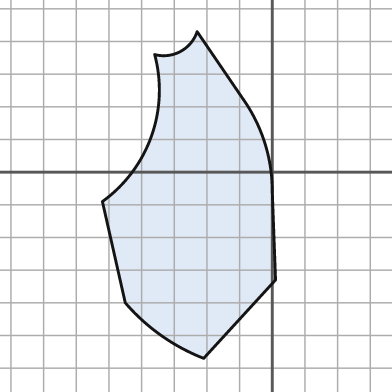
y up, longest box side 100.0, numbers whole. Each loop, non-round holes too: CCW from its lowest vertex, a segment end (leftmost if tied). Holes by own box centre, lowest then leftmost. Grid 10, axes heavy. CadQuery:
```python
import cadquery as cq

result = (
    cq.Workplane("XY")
    .moveTo(-21.0, -57.0)
    .lineTo(1.0, -33.0)
    .lineTo(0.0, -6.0)
    .threePointArc((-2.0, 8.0), (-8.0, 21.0))
    .lineTo(-23.0, 43.0)
    .threePointArc((-28.0, 37.0), (-36.0, 36.0))
    .threePointArc((-37.0, 11.0), (-52.0, -9.0))
    .lineTo(-45.0, -40.0)
    .threePointArc((-34.0, -50.0), (-21.0, -57.0))
    .close()
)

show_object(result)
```